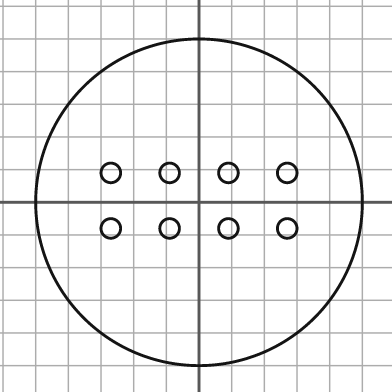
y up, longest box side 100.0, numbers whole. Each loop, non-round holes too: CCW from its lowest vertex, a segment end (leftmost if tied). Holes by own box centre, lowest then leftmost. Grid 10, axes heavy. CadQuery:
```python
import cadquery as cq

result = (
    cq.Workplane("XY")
    .moveTo(0.0, 0.0)
    .circle(50.0)
    .moveTo(-27.0, -8.0)
    .circle(3.0)
    .moveTo(-9.0, -8.0)
    .circle(3.0)
    .moveTo(9.0, -8.0)
    .circle(3.0)
    .moveTo(27.0, -8.0)
    .circle(3.0)
    .moveTo(-27.0, 9.0)
    .circle(3.0)
    .moveTo(-9.0, 9.0)
    .circle(3.0)
    .moveTo(9.0, 9.0)
    .circle(3.0)
    .moveTo(27.0, 9.0)
    .circle(3.0)
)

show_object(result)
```